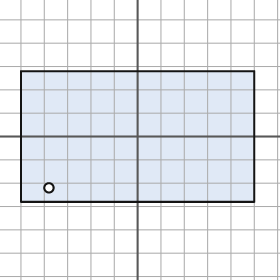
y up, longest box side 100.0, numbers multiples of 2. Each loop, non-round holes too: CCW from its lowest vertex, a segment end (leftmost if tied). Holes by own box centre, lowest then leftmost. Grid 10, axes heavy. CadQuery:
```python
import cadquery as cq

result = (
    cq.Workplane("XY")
    .moveTo(-50.0, -28.0)
    .lineTo(50.0, -28.0)
    .lineTo(50.0, 28.0)
    .lineTo(-50.0, 28.0)
    .close()
    .moveTo(-38.0, -22.0)
    .circle(2.0)
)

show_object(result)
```